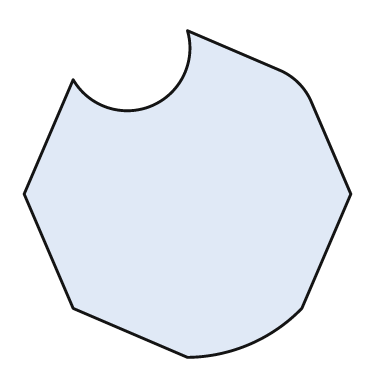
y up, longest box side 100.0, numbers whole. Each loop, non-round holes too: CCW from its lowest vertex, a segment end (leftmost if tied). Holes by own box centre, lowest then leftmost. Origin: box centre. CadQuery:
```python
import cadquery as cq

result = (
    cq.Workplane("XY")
    .moveTo(0.0, -50.0)
    .threePointArc((19.0, -46.0), (35.0, -35.0))
    .lineTo(50.0, 0.0)
    .lineTo(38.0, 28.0)
    .threePointArc((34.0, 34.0), (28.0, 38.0))
    .lineTo(0.0, 50.0)
    .threePointArc((-11.0, 27.0), (-35.0, 35.0))
    .lineTo(-50.0, 0.0)
    .lineTo(-35.0, -35.0)
    .close()
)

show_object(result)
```